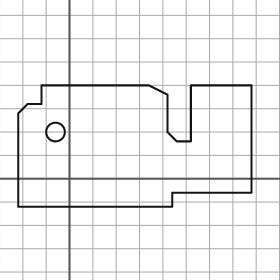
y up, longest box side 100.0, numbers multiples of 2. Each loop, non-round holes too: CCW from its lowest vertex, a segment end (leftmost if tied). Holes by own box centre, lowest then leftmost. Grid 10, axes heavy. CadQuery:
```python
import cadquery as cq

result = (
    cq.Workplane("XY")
    .moveTo(-22.0, -12.0)
    .lineTo(44.0, -12.0)
    .lineTo(44.0, -6.0)
    .lineTo(78.0, -6.0)
    .lineTo(78.0, 40.0)
    .lineTo(52.0, 40.0)
    .lineTo(52.0, 16.0)
    .lineTo(46.0, 16.0)
    .lineTo(42.0, 20.0)
    .lineTo(42.0, 36.0)
    .lineTo(34.0, 40.0)
    .lineTo(-12.0, 40.0)
    .lineTo(-12.0, 32.0)
    .lineTo(-18.0, 32.0)
    .lineTo(-22.0, 28.0)
    .close()
    .moveTo(-6.0, 20.0)
    .circle(4.0)
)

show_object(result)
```